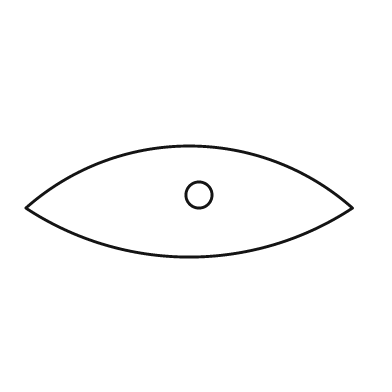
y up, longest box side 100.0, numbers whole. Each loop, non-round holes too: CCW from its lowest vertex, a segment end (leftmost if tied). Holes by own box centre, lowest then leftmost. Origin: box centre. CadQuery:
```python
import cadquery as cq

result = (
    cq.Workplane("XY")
    .moveTo(-50.0, -2.0)
    .threePointArc((0.0, -17.0), (50.0, -2.0))
    .threePointArc((0.0, 17.0), (-50.0, -2.0))
    .close()
    .moveTo(3.0, 2.0)
    .circle(4.0)
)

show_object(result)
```